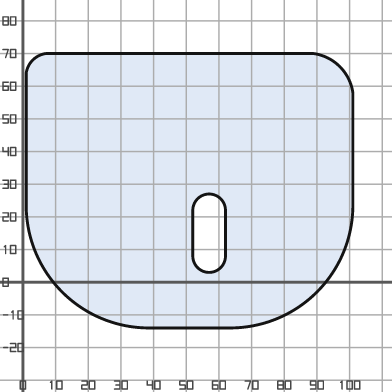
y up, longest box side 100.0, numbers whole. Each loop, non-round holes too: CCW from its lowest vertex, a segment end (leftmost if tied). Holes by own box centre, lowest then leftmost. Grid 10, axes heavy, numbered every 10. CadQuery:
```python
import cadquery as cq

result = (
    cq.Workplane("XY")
    .moveTo(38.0, -14.0)
    .lineTo(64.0, -14.0)
    .threePointArc((90.0, -3.0), (101.0, 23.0))
    .lineTo(101.0, 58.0)
    .threePointArc((97.0, 66.0), (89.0, 70.0))
    .lineTo(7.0, 70.0)
    .threePointArc((3.0, 68.0), (1.0, 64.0))
    .lineTo(1.0, 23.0)
    .threePointArc((12.0, -3.0), (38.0, -14.0))
    .close()
    .moveTo(52.0, 8.0)
    .threePointArc((57.0, 3.0), (62.0, 8.0))
    .lineTo(62.0, 22.0)
    .threePointArc((57.0, 27.0), (52.0, 22.0))
    .close()
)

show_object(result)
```